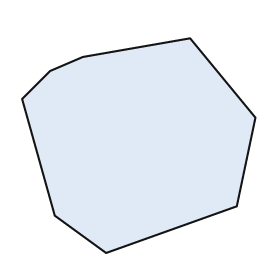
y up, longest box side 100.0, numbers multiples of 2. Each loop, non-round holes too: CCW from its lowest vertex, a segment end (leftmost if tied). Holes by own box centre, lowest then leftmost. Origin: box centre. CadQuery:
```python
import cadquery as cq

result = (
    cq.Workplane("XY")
    .moveTo(-14.0, -46.0)
    .lineTo(42.0, -26.0)
    .lineTo(50.0, 12.0)
    .lineTo(22.0, 46.0)
    .lineTo(-24.0, 38.0)
    .lineTo(-38.0, 32.0)
    .lineTo(-50.0, 20.0)
    .lineTo(-36.0, -30.0)
    .close()
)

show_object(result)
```